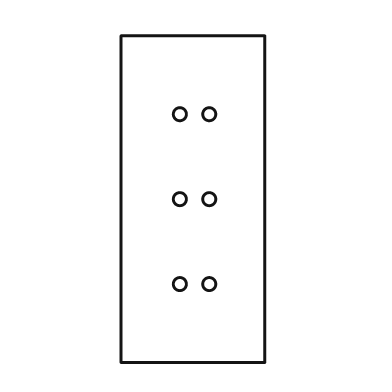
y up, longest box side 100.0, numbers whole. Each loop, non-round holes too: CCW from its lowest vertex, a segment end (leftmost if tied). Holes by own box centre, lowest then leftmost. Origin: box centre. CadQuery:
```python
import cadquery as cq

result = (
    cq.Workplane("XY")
    .moveTo(-22.0, -50.0)
    .lineTo(22.0, -50.0)
    .lineTo(22.0, 50.0)
    .lineTo(-22.0, 50.0)
    .close()
    .moveTo(-4.0, -26.0)
    .circle(2.0)
    .moveTo(5.0, -26.0)
    .circle(2.0)
    .moveTo(-4.0, 0.0)
    .circle(2.0)
    .moveTo(5.0, 0.0)
    .circle(2.0)
    .moveTo(-4.0, 26.0)
    .circle(2.0)
    .moveTo(5.0, 26.0)
    .circle(2.0)
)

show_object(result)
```